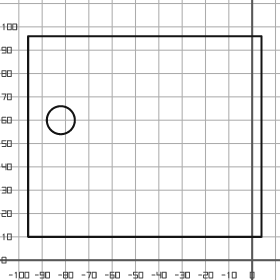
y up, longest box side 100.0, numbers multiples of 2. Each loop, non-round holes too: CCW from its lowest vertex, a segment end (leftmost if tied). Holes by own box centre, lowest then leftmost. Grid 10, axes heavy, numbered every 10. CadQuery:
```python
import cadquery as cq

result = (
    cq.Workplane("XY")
    .moveTo(-96.0, 10.0)
    .lineTo(4.0, 10.0)
    .lineTo(4.0, 96.0)
    .lineTo(-96.0, 96.0)
    .close()
    .moveTo(-82.0, 60.0)
    .circle(6.0)
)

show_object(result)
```